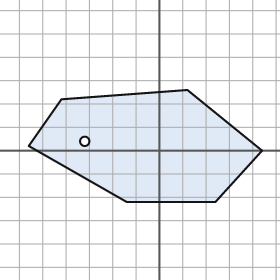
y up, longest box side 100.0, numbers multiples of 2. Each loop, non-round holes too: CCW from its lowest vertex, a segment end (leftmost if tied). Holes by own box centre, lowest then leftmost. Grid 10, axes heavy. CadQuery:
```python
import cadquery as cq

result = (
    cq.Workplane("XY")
    .moveTo(-14.0, -22.0)
    .lineTo(24.0, -22.0)
    .lineTo(44.0, 0.0)
    .lineTo(12.0, 26.0)
    .lineTo(-42.0, 22.0)
    .lineTo(-56.0, 2.0)
    .close()
    .moveTo(-32.0, 4.0)
    .circle(2.0)
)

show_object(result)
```